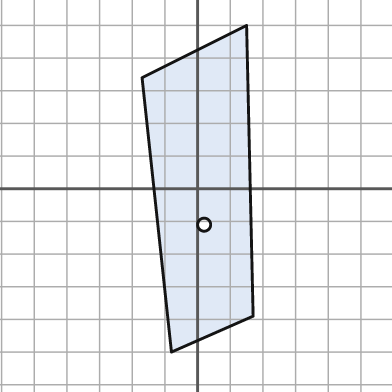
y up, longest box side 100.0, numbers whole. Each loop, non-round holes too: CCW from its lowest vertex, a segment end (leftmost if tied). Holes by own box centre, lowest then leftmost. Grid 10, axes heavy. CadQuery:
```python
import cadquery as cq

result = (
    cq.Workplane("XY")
    .moveTo(-8.0, -50.0)
    .lineTo(17.0, -39.0)
    .lineTo(15.0, 50.0)
    .lineTo(-17.0, 34.0)
    .close()
    .moveTo(2.0, -11.0)
    .circle(2.0)
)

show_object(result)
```